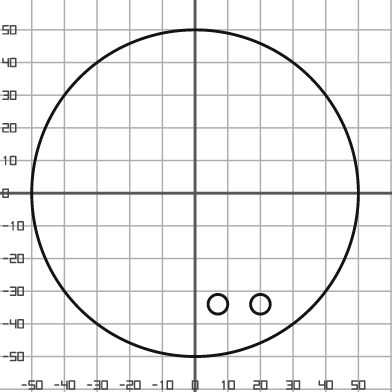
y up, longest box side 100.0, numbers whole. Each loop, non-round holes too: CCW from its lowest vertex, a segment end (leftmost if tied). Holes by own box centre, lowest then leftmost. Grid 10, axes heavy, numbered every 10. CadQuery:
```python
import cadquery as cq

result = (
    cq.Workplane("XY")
    .moveTo(0.0, 0.0)
    .circle(50.0)
    .moveTo(7.0, -34.0)
    .circle(3.0)
    .moveTo(20.0, -34.0)
    .circle(3.0)
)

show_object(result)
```